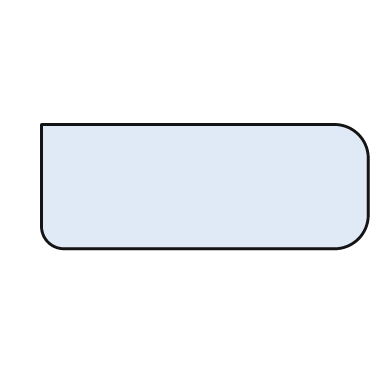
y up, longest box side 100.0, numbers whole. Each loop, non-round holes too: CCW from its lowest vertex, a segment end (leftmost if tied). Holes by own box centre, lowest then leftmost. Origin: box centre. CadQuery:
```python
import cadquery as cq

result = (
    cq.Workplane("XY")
    .moveTo(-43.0, -19.0)
    .lineTo(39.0, -19.0)
    .threePointArc((47.0, -16.0), (50.0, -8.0))
    .lineTo(50.0, 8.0)
    .threePointArc((47.0, 16.0), (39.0, 19.0))
    .lineTo(-50.0, 19.0)
    .lineTo(-50.0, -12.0)
    .threePointArc((-48.0, -17.0), (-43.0, -19.0))
    .close()
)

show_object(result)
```